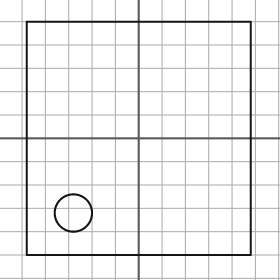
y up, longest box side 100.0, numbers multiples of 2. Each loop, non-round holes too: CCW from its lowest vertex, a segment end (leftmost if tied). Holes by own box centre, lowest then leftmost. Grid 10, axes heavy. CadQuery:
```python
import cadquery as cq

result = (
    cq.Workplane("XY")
    .moveTo(-48.0, -50.0)
    .lineTo(48.0, -50.0)
    .lineTo(48.0, 50.0)
    .lineTo(-48.0, 50.0)
    .close()
    .moveTo(-28.0, -32.0)
    .circle(8.0)
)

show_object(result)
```